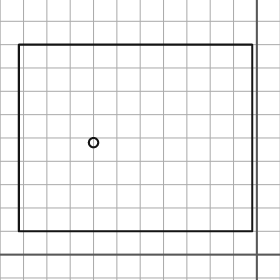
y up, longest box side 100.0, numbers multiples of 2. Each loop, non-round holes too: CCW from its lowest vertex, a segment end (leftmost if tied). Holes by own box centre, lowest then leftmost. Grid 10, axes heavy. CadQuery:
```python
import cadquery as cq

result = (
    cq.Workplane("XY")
    .moveTo(-102.0, 10.0)
    .lineTo(-2.0, 10.0)
    .lineTo(-2.0, 90.0)
    .lineTo(-102.0, 90.0)
    .close()
    .moveTo(-70.0, 48.0)
    .circle(2.0)
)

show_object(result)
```